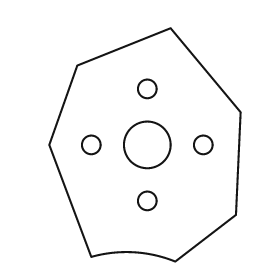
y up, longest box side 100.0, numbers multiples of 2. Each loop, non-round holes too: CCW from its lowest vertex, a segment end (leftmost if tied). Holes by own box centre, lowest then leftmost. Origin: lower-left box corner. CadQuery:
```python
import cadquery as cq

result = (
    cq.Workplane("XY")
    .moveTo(54.0, 0.0)
    .lineTo(80.0, 20.0)
    .lineTo(82.0, 64.0)
    .lineTo(52.0, 100.0)
    .lineTo(12.0, 84.0)
    .lineTo(0.0, 50.0)
    .lineTo(18.0, 2.0)
    .threePointArc((36.0, 4.0), (54.0, 0.0))
    .close()
    .moveTo(42.0, 26.0)
    .circle(4.0)
    .moveTo(18.0, 50.0)
    .circle(4.0)
    .moveTo(42.0, 50.0)
    .circle(10.0)
    .moveTo(66.0, 50.0)
    .circle(4.0)
    .moveTo(42.0, 74.0)
    .circle(4.0)
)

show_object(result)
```